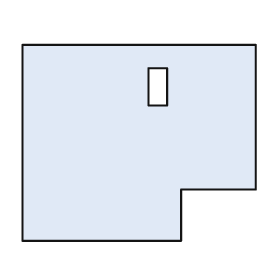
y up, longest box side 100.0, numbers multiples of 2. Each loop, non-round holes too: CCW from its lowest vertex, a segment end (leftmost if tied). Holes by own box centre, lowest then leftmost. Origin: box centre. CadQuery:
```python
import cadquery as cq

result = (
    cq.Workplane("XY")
    .moveTo(-50.0, -42.0)
    .lineTo(18.0, -42.0)
    .lineTo(18.0, -20.0)
    .lineTo(50.0, -20.0)
    .lineTo(50.0, 42.0)
    .lineTo(-50.0, 42.0)
    .close()
    .moveTo(4.0, 16.0)
    .lineTo(12.0, 16.0)
    .lineTo(12.0, 32.0)
    .lineTo(4.0, 32.0)
    .close()
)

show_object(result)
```